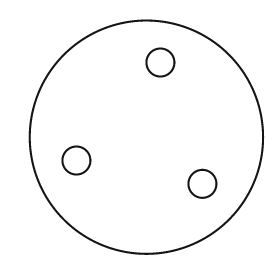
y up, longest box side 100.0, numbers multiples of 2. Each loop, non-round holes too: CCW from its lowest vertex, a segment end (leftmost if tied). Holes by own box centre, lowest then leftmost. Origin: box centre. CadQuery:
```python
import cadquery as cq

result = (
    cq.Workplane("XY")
    .moveTo(0.0, 0.0)
    .circle(50.0)
    .moveTo(24.0, -20.0)
    .circle(6.0)
    .moveTo(-30.0, -10.0)
    .circle(6.0)
    .moveTo(6.0, 32.0)
    .circle(6.0)
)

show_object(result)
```